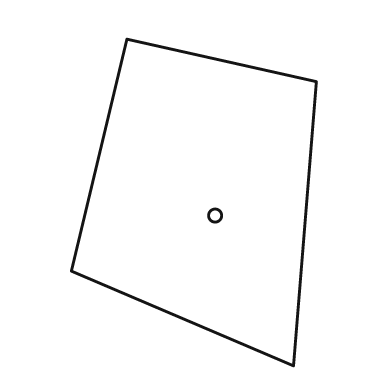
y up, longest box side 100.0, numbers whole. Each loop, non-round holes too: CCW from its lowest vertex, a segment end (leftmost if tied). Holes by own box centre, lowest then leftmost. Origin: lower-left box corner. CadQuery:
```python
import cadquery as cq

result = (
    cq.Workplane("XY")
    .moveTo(68.0, 0.0)
    .lineTo(75.0, 87.0)
    .lineTo(17.0, 100.0)
    .lineTo(0.0, 29.0)
    .close()
    .moveTo(44.0, 46.0)
    .circle(2.0)
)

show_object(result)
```